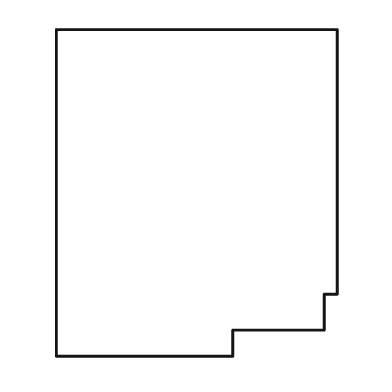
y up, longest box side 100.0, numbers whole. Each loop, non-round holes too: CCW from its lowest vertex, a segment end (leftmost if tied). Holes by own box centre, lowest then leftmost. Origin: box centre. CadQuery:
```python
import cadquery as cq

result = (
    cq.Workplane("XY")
    .moveTo(-43.0, -50.0)
    .lineTo(11.0, -50.0)
    .lineTo(11.0, -42.0)
    .lineTo(39.0, -42.0)
    .lineTo(39.0, -31.0)
    .lineTo(43.0, -31.0)
    .lineTo(43.0, 50.0)
    .lineTo(-43.0, 50.0)
    .close()
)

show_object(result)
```